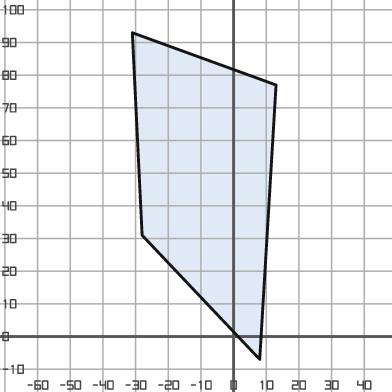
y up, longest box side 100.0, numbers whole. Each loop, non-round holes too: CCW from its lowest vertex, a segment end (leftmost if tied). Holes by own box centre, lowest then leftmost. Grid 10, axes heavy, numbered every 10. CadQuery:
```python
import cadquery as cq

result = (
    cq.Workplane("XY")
    .moveTo(8.0, -7.0)
    .lineTo(13.0, 77.0)
    .lineTo(-31.0, 93.0)
    .lineTo(-28.0, 31.0)
    .close()
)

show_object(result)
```